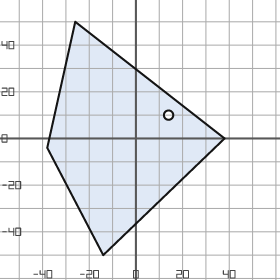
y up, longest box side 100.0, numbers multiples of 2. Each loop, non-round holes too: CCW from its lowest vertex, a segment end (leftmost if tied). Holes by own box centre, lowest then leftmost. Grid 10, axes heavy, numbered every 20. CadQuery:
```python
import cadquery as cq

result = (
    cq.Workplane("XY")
    .moveTo(-14.0, -50.0)
    .lineTo(38.0, 0.0)
    .lineTo(-26.0, 50.0)
    .lineTo(-38.0, -4.0)
    .close()
    .moveTo(14.0, 10.0)
    .circle(2.0)
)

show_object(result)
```